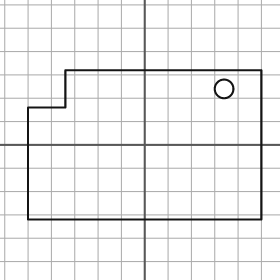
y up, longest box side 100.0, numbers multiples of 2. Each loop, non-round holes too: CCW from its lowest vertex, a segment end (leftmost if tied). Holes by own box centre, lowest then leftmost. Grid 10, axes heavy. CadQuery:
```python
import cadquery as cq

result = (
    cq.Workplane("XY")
    .moveTo(-50.0, -32.0)
    .lineTo(50.0, -32.0)
    .lineTo(50.0, 32.0)
    .lineTo(-34.0, 32.0)
    .lineTo(-34.0, 16.0)
    .lineTo(-50.0, 16.0)
    .close()
    .moveTo(34.0, 24.0)
    .circle(4.0)
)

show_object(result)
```